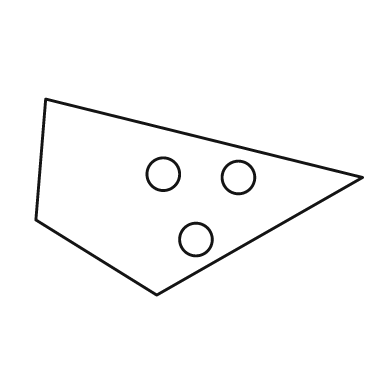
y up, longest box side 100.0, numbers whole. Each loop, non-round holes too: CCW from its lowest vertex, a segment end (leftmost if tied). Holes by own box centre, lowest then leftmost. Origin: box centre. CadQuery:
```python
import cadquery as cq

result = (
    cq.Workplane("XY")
    .moveTo(-13.0, -30.0)
    .lineTo(50.0, 6.0)
    .lineTo(-47.0, 30.0)
    .lineTo(-50.0, -7.0)
    .close()
    .moveTo(-1.0, -13.0)
    .circle(5.0)
    .moveTo(12.0, 6.0)
    .circle(5.0)
    .moveTo(-11.0, 7.0)
    .circle(5.0)
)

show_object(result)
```